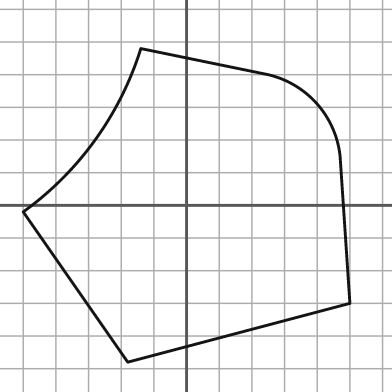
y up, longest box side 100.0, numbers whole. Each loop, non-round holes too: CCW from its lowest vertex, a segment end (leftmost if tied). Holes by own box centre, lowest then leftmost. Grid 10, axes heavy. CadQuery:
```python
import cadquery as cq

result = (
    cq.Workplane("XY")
    .moveTo(-18.0, -48.0)
    .lineTo(50.0, -30.0)
    .lineTo(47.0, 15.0)
    .threePointArc((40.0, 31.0), (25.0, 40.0))
    .lineTo(-14.0, 48.0)
    .threePointArc((-28.0, 20.0), (-50.0, -2.0))
    .close()
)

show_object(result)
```